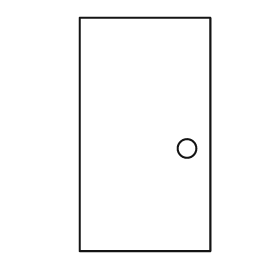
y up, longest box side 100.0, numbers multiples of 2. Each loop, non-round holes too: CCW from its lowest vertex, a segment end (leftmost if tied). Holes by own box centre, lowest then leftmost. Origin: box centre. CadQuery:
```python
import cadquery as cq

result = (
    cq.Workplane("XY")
    .moveTo(-28.0, -50.0)
    .lineTo(28.0, -50.0)
    .lineTo(28.0, 50.0)
    .lineTo(-28.0, 50.0)
    .close()
    .moveTo(18.0, -6.0)
    .circle(4.0)
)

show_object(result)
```